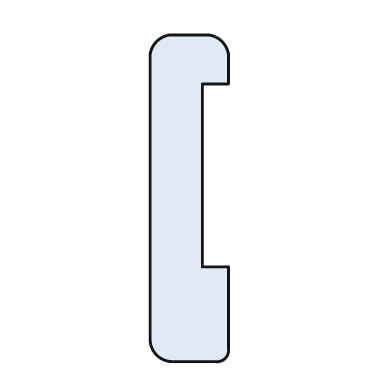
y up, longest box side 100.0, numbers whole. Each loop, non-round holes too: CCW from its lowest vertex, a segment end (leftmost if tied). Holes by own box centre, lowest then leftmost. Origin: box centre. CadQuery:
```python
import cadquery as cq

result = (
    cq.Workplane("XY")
    .moveTo(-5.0, -50.0)
    .lineTo(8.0, -50.0)
    .threePointArc((11.0, -49.0), (12.0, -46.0))
    .lineTo(12.0, -21.0)
    .lineTo(4.0, -21.0)
    .lineTo(4.0, 35.0)
    .lineTo(12.0, 35.0)
    .lineTo(12.0, 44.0)
    .threePointArc((10.0, 48.0), (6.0, 50.0))
    .lineTo(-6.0, 50.0)
    .threePointArc((-10.0, 48.0), (-12.0, 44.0))
    .lineTo(-12.0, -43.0)
    .threePointArc((-10.0, -48.0), (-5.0, -50.0))
    .close()
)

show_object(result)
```